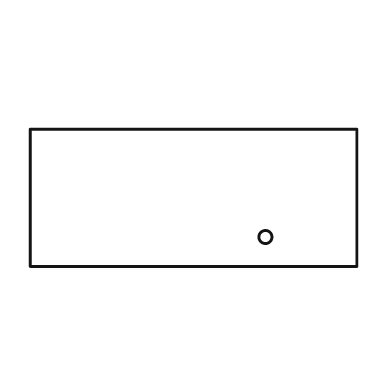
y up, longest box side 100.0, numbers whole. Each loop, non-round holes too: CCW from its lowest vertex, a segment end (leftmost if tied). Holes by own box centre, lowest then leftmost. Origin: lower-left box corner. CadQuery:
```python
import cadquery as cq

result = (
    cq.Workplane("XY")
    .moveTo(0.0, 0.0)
    .lineTo(100.0, 0.0)
    .lineTo(100.0, 42.0)
    .lineTo(0.0, 42.0)
    .close()
    .moveTo(72.0, 9.0)
    .circle(2.0)
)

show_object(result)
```